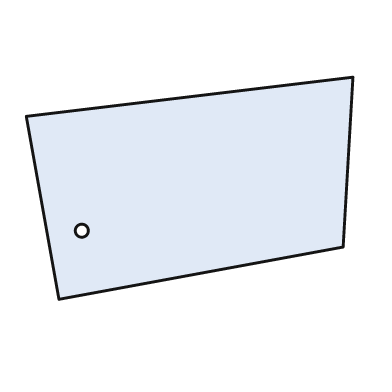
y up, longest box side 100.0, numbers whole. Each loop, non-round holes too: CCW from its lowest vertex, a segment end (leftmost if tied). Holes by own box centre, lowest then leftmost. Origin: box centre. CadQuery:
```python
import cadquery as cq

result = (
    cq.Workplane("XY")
    .moveTo(-40.0, -34.0)
    .lineTo(47.0, -18.0)
    .lineTo(50.0, 34.0)
    .lineTo(-50.0, 22.0)
    .close()
    .moveTo(-33.0, -13.0)
    .circle(2.0)
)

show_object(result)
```